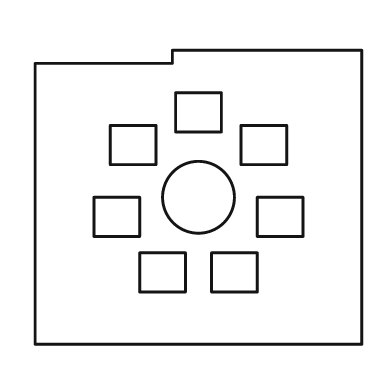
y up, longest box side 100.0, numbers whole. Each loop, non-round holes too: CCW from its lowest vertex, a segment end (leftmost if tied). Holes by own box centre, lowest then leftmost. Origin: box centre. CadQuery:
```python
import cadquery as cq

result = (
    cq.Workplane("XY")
    .moveTo(-50.0, -45.0)
    .lineTo(50.0, -45.0)
    .lineTo(50.0, 45.0)
    .lineTo(-8.0, 45.0)
    .lineTo(-8.0, 41.0)
    .lineTo(-50.0, 41.0)
    .close()
    .moveTo(-18.0, -29.0)
    .lineTo(-4.0, -29.0)
    .lineTo(-4.0, -17.0)
    .lineTo(-18.0, -17.0)
    .close()
    .moveTo(4.0, -29.0)
    .lineTo(18.0, -29.0)
    .lineTo(18.0, -17.0)
    .lineTo(4.0, -17.0)
    .close()
    .moveTo(-32.0, -12.0)
    .lineTo(-18.0, -12.0)
    .lineTo(-18.0, 0.0)
    .lineTo(-32.0, 0.0)
    .close()
    .moveTo(18.0, -12.0)
    .lineTo(32.0, -12.0)
    .lineTo(32.0, 0.0)
    .lineTo(18.0, 0.0)
    .close()
    .moveTo(0.0, 0.0)
    .circle(11.0)
    .moveTo(-27.0, 10.0)
    .lineTo(-13.0, 10.0)
    .lineTo(-13.0, 22.0)
    .lineTo(-27.0, 22.0)
    .close()
    .moveTo(13.0, 10.0)
    .lineTo(27.0, 10.0)
    .lineTo(27.0, 22.0)
    .lineTo(13.0, 22.0)
    .close()
    .moveTo(-7.0, 20.0)
    .lineTo(7.0, 20.0)
    .lineTo(7.0, 32.0)
    .lineTo(-7.0, 32.0)
    .close()
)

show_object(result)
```